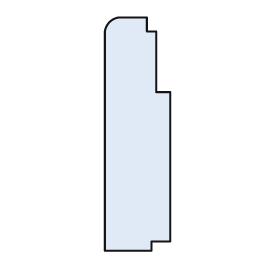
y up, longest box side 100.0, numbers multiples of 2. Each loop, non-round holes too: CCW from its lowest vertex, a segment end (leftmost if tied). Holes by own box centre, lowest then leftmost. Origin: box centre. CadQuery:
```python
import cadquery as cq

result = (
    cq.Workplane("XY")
    .moveTo(-14.0, -50.0)
    .lineTo(6.0, -50.0)
    .lineTo(6.0, -46.0)
    .lineTo(14.0, -46.0)
    .lineTo(14.0, 18.0)
    .lineTo(8.0, 18.0)
    .lineTo(8.0, 44.0)
    .lineTo(4.0, 44.0)
    .lineTo(4.0, 50.0)
    .lineTo(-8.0, 50.0)
    .threePointArc((-12.0, 48.0), (-14.0, 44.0))
    .close()
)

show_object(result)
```